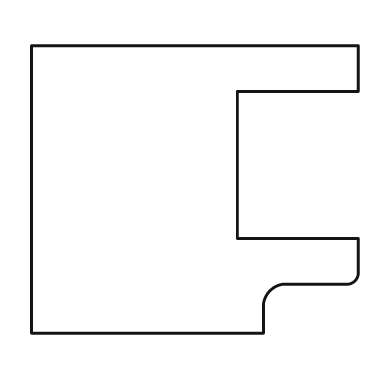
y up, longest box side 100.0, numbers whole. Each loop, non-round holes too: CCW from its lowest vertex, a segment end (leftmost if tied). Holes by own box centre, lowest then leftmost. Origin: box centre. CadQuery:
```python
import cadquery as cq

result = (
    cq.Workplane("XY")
    .moveTo(-50.0, -44.0)
    .lineTo(21.0, -44.0)
    .lineTo(21.0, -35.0)
    .threePointArc((23.0, -31.0), (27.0, -29.0))
    .lineTo(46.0, -29.0)
    .threePointArc((49.0, -28.0), (50.0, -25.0))
    .lineTo(50.0, -15.0)
    .lineTo(13.0, -15.0)
    .lineTo(13.0, 30.0)
    .lineTo(50.0, 30.0)
    .lineTo(50.0, 44.0)
    .lineTo(-50.0, 44.0)
    .close()
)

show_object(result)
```